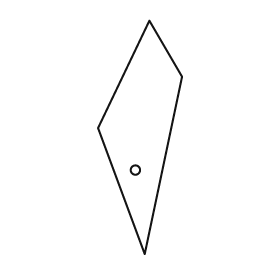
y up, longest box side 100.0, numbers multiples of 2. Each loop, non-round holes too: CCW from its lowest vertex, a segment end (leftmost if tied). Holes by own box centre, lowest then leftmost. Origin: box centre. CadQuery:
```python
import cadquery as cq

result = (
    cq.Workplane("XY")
    .moveTo(2.0, -50.0)
    .lineTo(18.0, 26.0)
    .lineTo(4.0, 50.0)
    .lineTo(-18.0, 4.0)
    .close()
    .moveTo(-2.0, -14.0)
    .circle(2.0)
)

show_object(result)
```